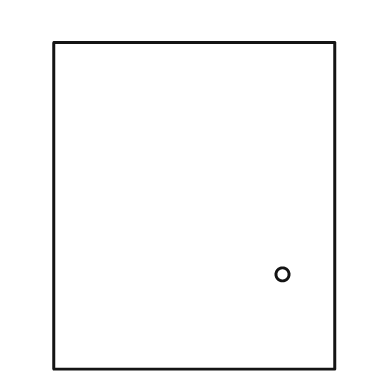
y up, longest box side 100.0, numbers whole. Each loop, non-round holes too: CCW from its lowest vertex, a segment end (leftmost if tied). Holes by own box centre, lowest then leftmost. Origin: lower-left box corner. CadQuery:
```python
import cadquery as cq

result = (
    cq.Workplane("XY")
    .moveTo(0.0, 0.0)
    .lineTo(86.0, 0.0)
    .lineTo(86.0, 100.0)
    .lineTo(0.0, 100.0)
    .close()
    .moveTo(70.0, 29.0)
    .circle(2.0)
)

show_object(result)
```